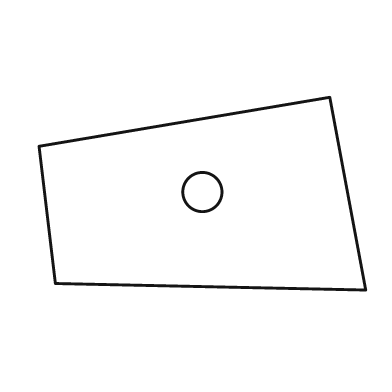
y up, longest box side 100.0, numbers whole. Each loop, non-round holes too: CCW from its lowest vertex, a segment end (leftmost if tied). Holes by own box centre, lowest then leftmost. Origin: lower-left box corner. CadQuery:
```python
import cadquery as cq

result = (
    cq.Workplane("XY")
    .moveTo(100.0, 0.0)
    .lineTo(89.0, 59.0)
    .lineTo(0.0, 44.0)
    .lineTo(5.0, 2.0)
    .close()
    .moveTo(50.0, 30.0)
    .circle(6.0)
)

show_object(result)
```